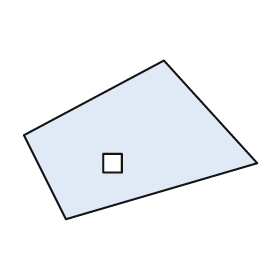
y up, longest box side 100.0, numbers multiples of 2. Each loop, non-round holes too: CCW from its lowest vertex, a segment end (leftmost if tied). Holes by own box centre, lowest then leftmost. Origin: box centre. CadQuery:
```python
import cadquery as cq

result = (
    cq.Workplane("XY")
    .moveTo(-32.0, -34.0)
    .lineTo(50.0, -10.0)
    .lineTo(10.0, 34.0)
    .lineTo(-50.0, 2.0)
    .close()
    .moveTo(-16.0, -14.0)
    .lineTo(-8.0, -14.0)
    .lineTo(-8.0, -6.0)
    .lineTo(-16.0, -6.0)
    .close()
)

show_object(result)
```